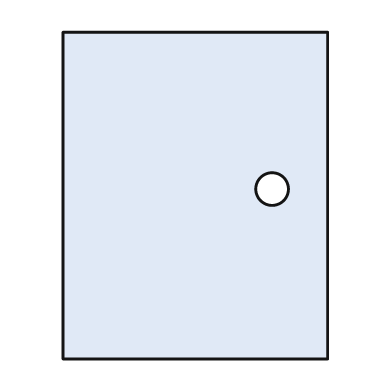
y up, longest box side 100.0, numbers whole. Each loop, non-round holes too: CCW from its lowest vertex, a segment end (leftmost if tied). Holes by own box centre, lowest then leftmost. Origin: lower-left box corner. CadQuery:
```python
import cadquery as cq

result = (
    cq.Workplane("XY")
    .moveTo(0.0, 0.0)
    .lineTo(81.0, 0.0)
    .lineTo(81.0, 100.0)
    .lineTo(0.0, 100.0)
    .close()
    .moveTo(64.0, 52.0)
    .circle(5.0)
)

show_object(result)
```